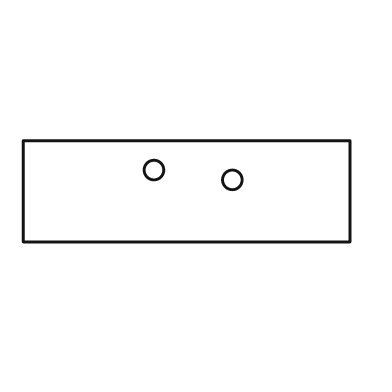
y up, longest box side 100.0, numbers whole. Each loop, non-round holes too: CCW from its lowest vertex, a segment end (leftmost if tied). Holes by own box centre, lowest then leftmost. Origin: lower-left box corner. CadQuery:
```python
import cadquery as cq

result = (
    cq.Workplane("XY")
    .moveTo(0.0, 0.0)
    .lineTo(100.0, 0.0)
    .lineTo(100.0, 31.0)
    .lineTo(0.0, 31.0)
    .close()
    .moveTo(64.0, 19.0)
    .circle(3.0)
    .moveTo(40.0, 22.0)
    .circle(3.0)
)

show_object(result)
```